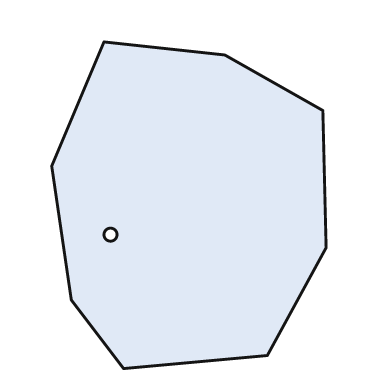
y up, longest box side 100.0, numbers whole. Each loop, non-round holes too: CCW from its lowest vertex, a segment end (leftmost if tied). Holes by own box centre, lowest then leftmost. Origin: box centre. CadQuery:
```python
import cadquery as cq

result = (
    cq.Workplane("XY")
    .moveTo(-20.0, -50.0)
    .lineTo(24.0, -46.0)
    .lineTo(42.0, -13.0)
    .lineTo(41.0, 29.0)
    .lineTo(11.0, 46.0)
    .lineTo(-26.0, 50.0)
    .lineTo(-42.0, 12.0)
    .lineTo(-36.0, -29.0)
    .close()
    .moveTo(-24.0, -9.0)
    .circle(2.0)
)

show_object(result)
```